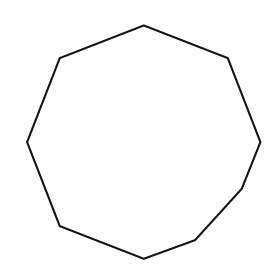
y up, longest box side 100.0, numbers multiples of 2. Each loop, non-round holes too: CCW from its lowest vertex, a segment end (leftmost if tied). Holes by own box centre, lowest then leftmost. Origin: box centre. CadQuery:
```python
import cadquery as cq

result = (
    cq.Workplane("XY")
    .moveTo(0.0, -50.0)
    .lineTo(22.0, -42.0)
    .lineTo(42.0, -20.0)
    .lineTo(50.0, 0.0)
    .lineTo(36.0, 36.0)
    .lineTo(0.0, 50.0)
    .lineTo(-36.0, 36.0)
    .lineTo(-50.0, 0.0)
    .lineTo(-36.0, -36.0)
    .close()
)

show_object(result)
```